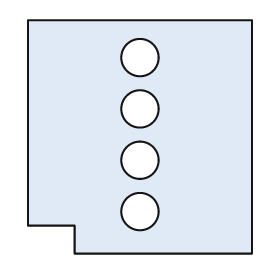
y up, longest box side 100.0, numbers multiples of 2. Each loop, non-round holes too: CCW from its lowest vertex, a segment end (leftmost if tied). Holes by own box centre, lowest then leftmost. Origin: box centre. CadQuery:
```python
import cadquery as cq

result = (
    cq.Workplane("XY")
    .moveTo(-28.0, -50.0)
    .lineTo(48.0, -50.0)
    .lineTo(48.0, 50.0)
    .lineTo(-48.0, 50.0)
    .lineTo(-48.0, -38.0)
    .lineTo(-28.0, -38.0)
    .close()
    .moveTo(0.0, -32.0)
    .circle(8.0)
    .moveTo(0.0, -10.0)
    .circle(8.0)
    .moveTo(0.0, 12.0)
    .circle(8.0)
    .moveTo(0.0, 34.0)
    .circle(8.0)
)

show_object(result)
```